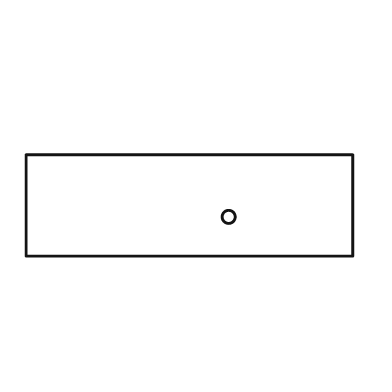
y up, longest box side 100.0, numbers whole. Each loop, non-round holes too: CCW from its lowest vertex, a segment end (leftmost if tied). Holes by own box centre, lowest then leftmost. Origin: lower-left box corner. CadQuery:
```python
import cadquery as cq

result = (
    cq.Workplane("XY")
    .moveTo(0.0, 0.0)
    .lineTo(100.0, 0.0)
    .lineTo(100.0, 31.0)
    .lineTo(0.0, 31.0)
    .close()
    .moveTo(62.0, 12.0)
    .circle(2.0)
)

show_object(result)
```